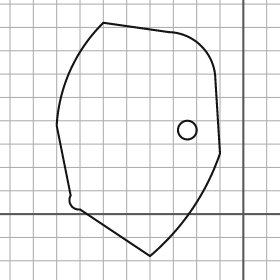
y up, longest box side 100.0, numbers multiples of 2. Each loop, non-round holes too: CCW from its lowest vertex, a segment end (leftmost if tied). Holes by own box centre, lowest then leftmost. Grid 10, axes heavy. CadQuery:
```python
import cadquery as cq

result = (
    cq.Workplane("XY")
    .moveTo(-40.0, -18.0)
    .threePointArc((-22.0, 2.0), (-10.0, 26.0))
    .lineTo(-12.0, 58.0)
    .threePointArc((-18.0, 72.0), (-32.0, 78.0))
    .lineTo(-60.0, 82.0)
    .threePointArc((-74.0, 62.0), (-80.0, 38.0))
    .lineTo(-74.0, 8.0)
    .threePointArc((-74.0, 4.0), (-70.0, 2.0))
    .close()
    .moveTo(-24.0, 36.0)
    .circle(4.0)
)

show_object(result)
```